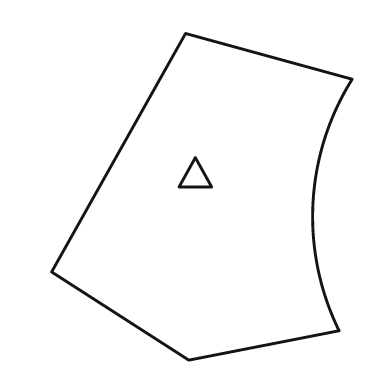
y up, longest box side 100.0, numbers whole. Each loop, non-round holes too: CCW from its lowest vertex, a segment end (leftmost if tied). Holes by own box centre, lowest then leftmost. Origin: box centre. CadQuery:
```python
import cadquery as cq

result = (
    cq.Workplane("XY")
    .moveTo(-4.0, -50.0)
    .lineTo(42.0, -41.0)
    .threePointArc((34.0, -2.0), (46.0, 36.0))
    .lineTo(-5.0, 50.0)
    .lineTo(-46.0, -23.0)
    .close()
    .moveTo(-7.0, 3.0)
    .lineTo(3.0, 3.0)
    .lineTo(-2.0, 12.0)
    .close()
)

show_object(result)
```